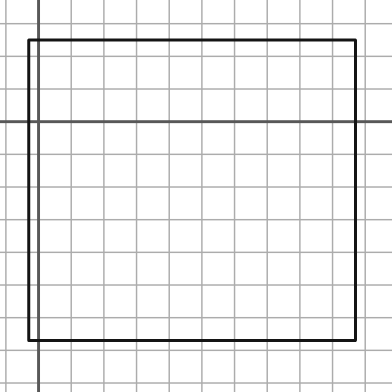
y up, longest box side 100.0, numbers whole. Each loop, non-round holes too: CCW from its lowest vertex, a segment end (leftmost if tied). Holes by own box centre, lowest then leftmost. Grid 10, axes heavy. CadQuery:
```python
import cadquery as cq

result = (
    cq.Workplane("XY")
    .moveTo(-3.0, -67.0)
    .lineTo(97.0, -67.0)
    .lineTo(97.0, 25.0)
    .lineTo(-3.0, 25.0)
    .close()
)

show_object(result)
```